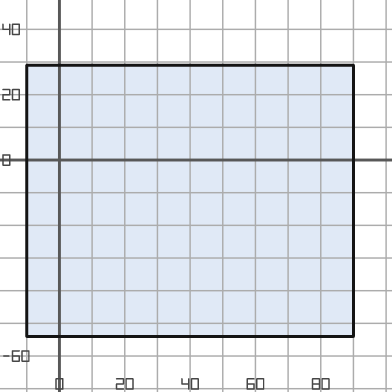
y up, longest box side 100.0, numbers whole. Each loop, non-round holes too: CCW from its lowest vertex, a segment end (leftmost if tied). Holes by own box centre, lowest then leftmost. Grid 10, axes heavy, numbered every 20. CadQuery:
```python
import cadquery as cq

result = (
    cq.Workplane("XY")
    .moveTo(-10.0, -54.0)
    .lineTo(90.0, -54.0)
    .lineTo(90.0, 29.0)
    .lineTo(-10.0, 29.0)
    .close()
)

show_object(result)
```